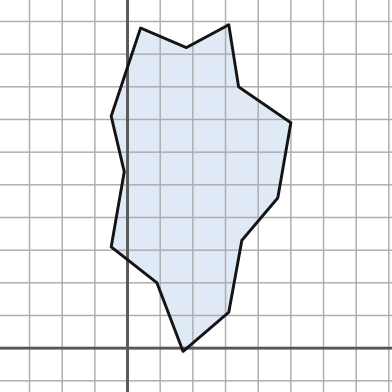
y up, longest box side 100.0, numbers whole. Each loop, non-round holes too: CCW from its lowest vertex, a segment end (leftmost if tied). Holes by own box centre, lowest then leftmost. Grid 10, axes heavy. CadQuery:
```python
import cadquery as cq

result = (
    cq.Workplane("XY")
    .moveTo(17.0, -1.0)
    .lineTo(31.0, 11.0)
    .lineTo(35.0, 33.0)
    .lineTo(46.0, 46.0)
    .lineTo(50.0, 69.0)
    .lineTo(34.0, 80.0)
    .lineTo(31.0, 99.0)
    .lineTo(18.0, 92.0)
    .lineTo(4.0, 98.0)
    .lineTo(-5.0, 71.0)
    .lineTo(-1.0, 54.0)
    .lineTo(-5.0, 31.0)
    .lineTo(9.0, 20.0)
    .close()
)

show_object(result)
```